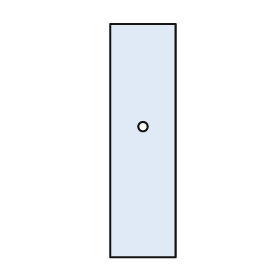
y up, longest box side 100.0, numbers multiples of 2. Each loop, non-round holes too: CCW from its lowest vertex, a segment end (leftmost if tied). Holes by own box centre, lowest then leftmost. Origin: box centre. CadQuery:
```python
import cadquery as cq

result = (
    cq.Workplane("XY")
    .moveTo(-14.0, -50.0)
    .lineTo(14.0, -50.0)
    .lineTo(14.0, 50.0)
    .lineTo(-14.0, 50.0)
    .close()
    .moveTo(0.0, 6.0)
    .circle(2.0)
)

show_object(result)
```